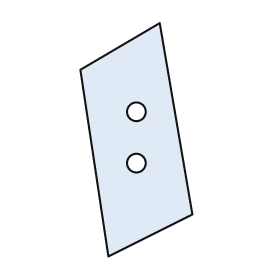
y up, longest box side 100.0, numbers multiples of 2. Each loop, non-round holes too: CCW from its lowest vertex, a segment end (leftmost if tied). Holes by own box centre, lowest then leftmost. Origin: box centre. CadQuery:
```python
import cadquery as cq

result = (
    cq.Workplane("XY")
    .moveTo(-12.0, -50.0)
    .lineTo(24.0, -32.0)
    .lineTo(10.0, 50.0)
    .lineTo(-24.0, 30.0)
    .close()
    .moveTo(0.0, -10.0)
    .circle(4.0)
    .moveTo(0.0, 12.0)
    .circle(4.0)
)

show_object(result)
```